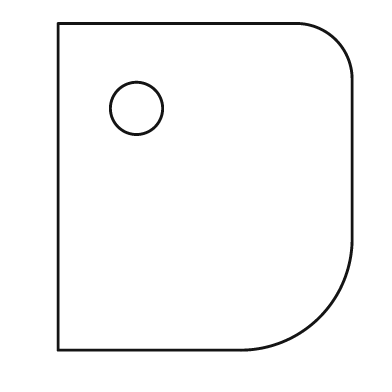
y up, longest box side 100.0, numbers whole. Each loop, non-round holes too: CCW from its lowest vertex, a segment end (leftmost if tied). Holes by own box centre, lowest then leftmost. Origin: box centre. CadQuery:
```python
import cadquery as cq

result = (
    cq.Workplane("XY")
    .moveTo(-45.0, -50.0)
    .lineTo(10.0, -50.0)
    .threePointArc((35.0, -40.0), (45.0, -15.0))
    .lineTo(45.0, 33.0)
    .threePointArc((40.0, 45.0), (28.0, 50.0))
    .lineTo(-45.0, 50.0)
    .close()
    .moveTo(-21.0, 24.0)
    .circle(8.0)
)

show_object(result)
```